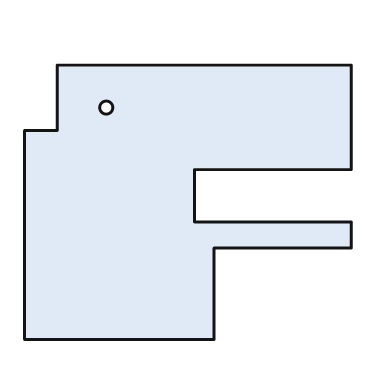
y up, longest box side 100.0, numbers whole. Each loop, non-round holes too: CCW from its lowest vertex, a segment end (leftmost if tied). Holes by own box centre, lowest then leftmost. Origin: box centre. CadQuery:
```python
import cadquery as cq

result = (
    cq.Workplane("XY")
    .moveTo(-50.0, -42.0)
    .lineTo(8.0, -42.0)
    .lineTo(8.0, -14.0)
    .lineTo(50.0, -14.0)
    .lineTo(50.0, -6.0)
    .lineTo(2.0, -6.0)
    .lineTo(2.0, 10.0)
    .lineTo(50.0, 10.0)
    .lineTo(50.0, 42.0)
    .lineTo(-40.0, 42.0)
    .lineTo(-40.0, 22.0)
    .lineTo(-50.0, 22.0)
    .close()
    .moveTo(-25.0, 29.0)
    .circle(2.0)
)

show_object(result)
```